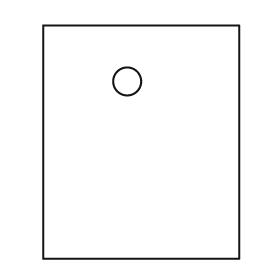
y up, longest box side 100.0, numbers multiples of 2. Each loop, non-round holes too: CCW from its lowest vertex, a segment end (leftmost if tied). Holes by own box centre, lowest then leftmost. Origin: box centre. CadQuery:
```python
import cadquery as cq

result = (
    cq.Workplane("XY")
    .moveTo(-42.0, -50.0)
    .lineTo(42.0, -50.0)
    .lineTo(42.0, 50.0)
    .lineTo(-42.0, 50.0)
    .close()
    .moveTo(-6.0, 26.0)
    .circle(6.0)
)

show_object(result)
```